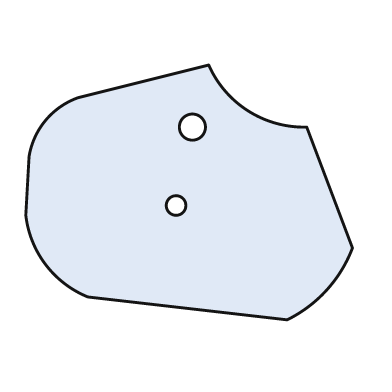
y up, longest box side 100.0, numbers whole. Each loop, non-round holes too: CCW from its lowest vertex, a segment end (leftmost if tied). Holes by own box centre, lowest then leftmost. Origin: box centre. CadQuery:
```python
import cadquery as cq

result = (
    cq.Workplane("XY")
    .moveTo(30.0, -39.0)
    .threePointArc((42.0, -30.0), (50.0, -17.0))
    .lineTo(36.0, 20.0)
    .threePointArc((18.0, 25.0), (6.0, 39.0))
    .lineTo(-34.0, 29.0)
    .threePointArc((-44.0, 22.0), (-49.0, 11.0))
    .lineTo(-50.0, -7.0)
    .threePointArc((-44.0, -22.0), (-31.0, -32.0))
    .close()
    .moveTo(-4.0, -4.0)
    .circle(3.0)
    .moveTo(1.0, 20.0)
    .circle(4.0)
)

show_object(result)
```